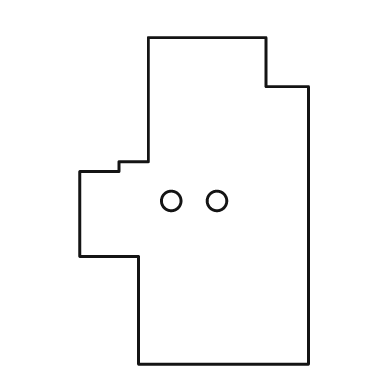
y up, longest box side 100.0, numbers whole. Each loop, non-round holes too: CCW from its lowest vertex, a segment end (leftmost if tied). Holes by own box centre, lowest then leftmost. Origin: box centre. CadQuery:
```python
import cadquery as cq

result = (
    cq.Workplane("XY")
    .moveTo(-17.0, -50.0)
    .lineTo(35.0, -50.0)
    .lineTo(35.0, 35.0)
    .lineTo(22.0, 35.0)
    .lineTo(22.0, 50.0)
    .lineTo(-14.0, 50.0)
    .lineTo(-14.0, 12.0)
    .lineTo(-23.0, 12.0)
    .lineTo(-23.0, 9.0)
    .lineTo(-35.0, 9.0)
    .lineTo(-35.0, -17.0)
    .lineTo(-17.0, -17.0)
    .close()
    .moveTo(-7.0, 0.0)
    .circle(3.0)
    .moveTo(7.0, 0.0)
    .circle(3.0)
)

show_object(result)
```